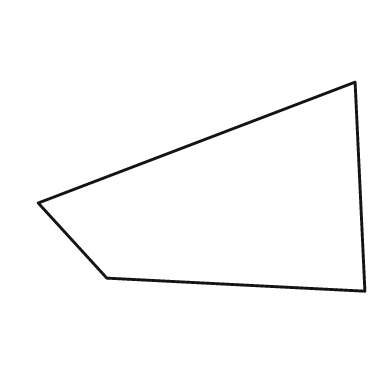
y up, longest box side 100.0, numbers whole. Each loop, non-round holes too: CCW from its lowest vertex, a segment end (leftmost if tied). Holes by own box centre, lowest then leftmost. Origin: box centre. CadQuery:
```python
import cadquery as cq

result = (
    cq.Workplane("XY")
    .moveTo(50.0, -32.0)
    .lineTo(47.0, 32.0)
    .lineTo(-50.0, -5.0)
    .lineTo(-29.0, -28.0)
    .close()
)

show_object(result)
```